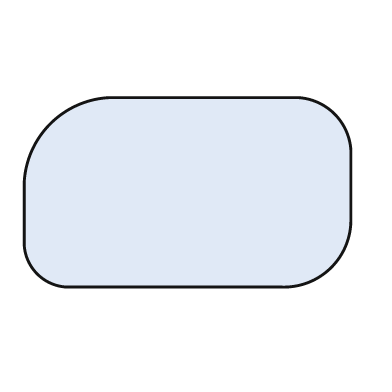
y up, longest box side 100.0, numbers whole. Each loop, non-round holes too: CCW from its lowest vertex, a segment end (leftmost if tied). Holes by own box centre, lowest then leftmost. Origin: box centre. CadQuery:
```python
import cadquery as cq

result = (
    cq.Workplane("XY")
    .moveTo(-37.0, -29.0)
    .lineTo(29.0, -29.0)
    .threePointArc((44.0, -23.0), (50.0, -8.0))
    .lineTo(50.0, 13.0)
    .threePointArc((45.0, 24.0), (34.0, 29.0))
    .lineTo(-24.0, 29.0)
    .threePointArc((-42.0, 21.0), (-50.0, 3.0))
    .lineTo(-50.0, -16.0)
    .threePointArc((-46.0, -25.0), (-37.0, -29.0))
    .close()
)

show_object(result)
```